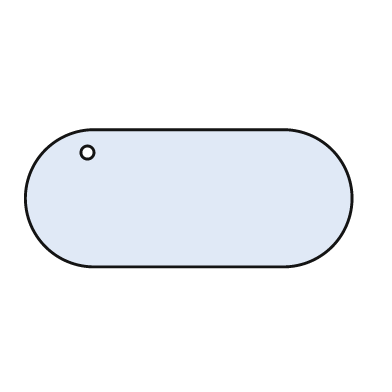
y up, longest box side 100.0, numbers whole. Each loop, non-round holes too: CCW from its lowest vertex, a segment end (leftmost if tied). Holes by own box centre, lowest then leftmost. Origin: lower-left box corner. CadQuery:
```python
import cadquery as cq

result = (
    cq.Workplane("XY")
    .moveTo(21.0, 0.0)
    .lineTo(79.0, 0.0)
    .threePointArc((100.0, 21.0), (79.0, 42.0))
    .lineTo(21.0, 42.0)
    .threePointArc((0.0, 21.0), (21.0, 0.0))
    .close()
    .moveTo(19.0, 35.0)
    .circle(2.0)
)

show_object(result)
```